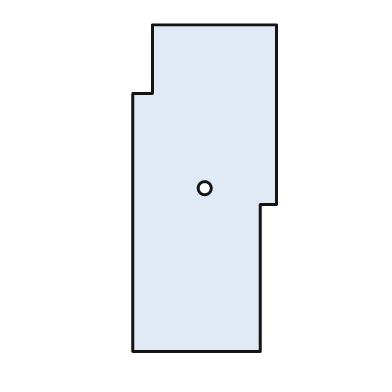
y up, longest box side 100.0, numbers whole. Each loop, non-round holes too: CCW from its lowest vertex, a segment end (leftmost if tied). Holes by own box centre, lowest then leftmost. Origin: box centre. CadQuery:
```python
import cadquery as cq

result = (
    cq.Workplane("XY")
    .moveTo(-22.0, -50.0)
    .lineTo(17.0, -50.0)
    .lineTo(17.0, -5.0)
    .lineTo(22.0, -5.0)
    .lineTo(22.0, 50.0)
    .lineTo(-16.0, 50.0)
    .lineTo(-16.0, 29.0)
    .lineTo(-22.0, 29.0)
    .close()
    .moveTo(0.0, 0.0)
    .circle(2.0)
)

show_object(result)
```